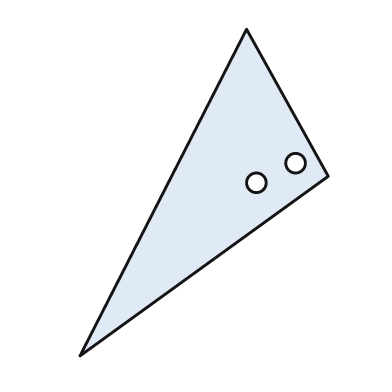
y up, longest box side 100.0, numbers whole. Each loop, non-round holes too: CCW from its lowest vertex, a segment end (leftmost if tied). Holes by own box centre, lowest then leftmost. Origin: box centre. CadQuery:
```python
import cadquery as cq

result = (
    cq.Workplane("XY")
    .moveTo(-38.0, -50.0)
    .lineTo(38.0, 5.0)
    .lineTo(13.0, 50.0)
    .close()
    .moveTo(16.0, 3.0)
    .circle(3.0)
    .moveTo(28.0, 9.0)
    .circle(3.0)
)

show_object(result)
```